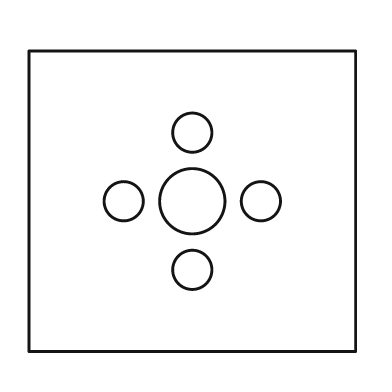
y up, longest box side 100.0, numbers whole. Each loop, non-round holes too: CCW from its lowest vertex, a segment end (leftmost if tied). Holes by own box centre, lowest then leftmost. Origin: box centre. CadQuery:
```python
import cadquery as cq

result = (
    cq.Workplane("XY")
    .moveTo(-50.0, -46.0)
    .lineTo(50.0, -46.0)
    .lineTo(50.0, 46.0)
    .lineTo(-50.0, 46.0)
    .close()
    .moveTo(0.0, -21.0)
    .circle(6.0)
    .moveTo(-21.0, 0.0)
    .circle(6.0)
    .moveTo(0.0, 0.0)
    .circle(10.0)
    .moveTo(21.0, 0.0)
    .circle(6.0)
    .moveTo(0.0, 21.0)
    .circle(6.0)
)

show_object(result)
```